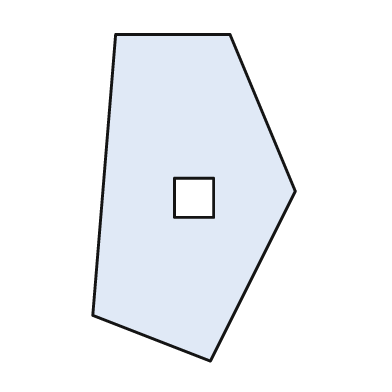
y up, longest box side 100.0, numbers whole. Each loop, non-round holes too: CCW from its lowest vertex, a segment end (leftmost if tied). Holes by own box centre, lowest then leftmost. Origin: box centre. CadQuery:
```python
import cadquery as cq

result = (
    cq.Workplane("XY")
    .moveTo(5.0, -50.0)
    .lineTo(31.0, 2.0)
    .lineTo(11.0, 50.0)
    .lineTo(-24.0, 50.0)
    .lineTo(-31.0, -36.0)
    .close()
    .moveTo(-6.0, -6.0)
    .lineTo(6.0, -6.0)
    .lineTo(6.0, 6.0)
    .lineTo(-6.0, 6.0)
    .close()
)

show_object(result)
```